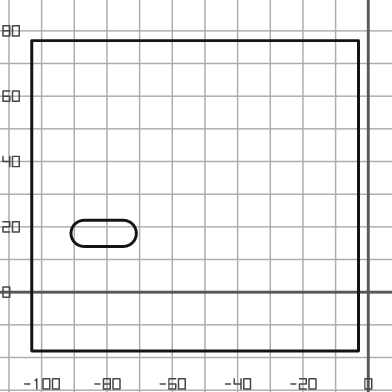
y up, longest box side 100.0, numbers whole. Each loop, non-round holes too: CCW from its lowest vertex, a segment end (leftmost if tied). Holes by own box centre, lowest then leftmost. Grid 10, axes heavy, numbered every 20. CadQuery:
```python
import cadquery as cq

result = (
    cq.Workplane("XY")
    .moveTo(-103.0, -18.0)
    .lineTo(-3.0, -18.0)
    .lineTo(-3.0, 77.0)
    .lineTo(-103.0, 77.0)
    .close()
    .moveTo(-87.0, 14.0)
    .lineTo(-75.0, 14.0)
    .threePointArc((-71.0, 18.0), (-75.0, 22.0))
    .lineTo(-87.0, 22.0)
    .threePointArc((-91.0, 18.0), (-87.0, 14.0))
    .close()
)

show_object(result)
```